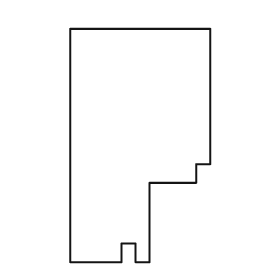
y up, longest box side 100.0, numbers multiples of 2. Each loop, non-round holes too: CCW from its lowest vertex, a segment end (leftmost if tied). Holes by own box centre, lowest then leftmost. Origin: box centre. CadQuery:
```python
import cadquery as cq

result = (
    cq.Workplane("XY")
    .moveTo(-30.0, -50.0)
    .lineTo(-8.0, -50.0)
    .lineTo(-8.0, -42.0)
    .lineTo(-2.0, -42.0)
    .lineTo(-2.0, -50.0)
    .lineTo(4.0, -50.0)
    .lineTo(4.0, -16.0)
    .lineTo(24.0, -16.0)
    .lineTo(24.0, -8.0)
    .lineTo(30.0, -8.0)
    .lineTo(30.0, 50.0)
    .lineTo(-30.0, 50.0)
    .close()
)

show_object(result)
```